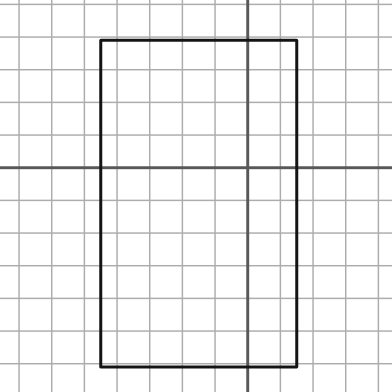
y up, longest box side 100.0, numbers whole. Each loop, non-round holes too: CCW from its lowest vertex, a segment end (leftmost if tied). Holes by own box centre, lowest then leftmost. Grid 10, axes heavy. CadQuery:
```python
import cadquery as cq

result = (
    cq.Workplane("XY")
    .moveTo(-45.0, -61.0)
    .lineTo(15.0, -61.0)
    .lineTo(15.0, 39.0)
    .lineTo(-45.0, 39.0)
    .close()
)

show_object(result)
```